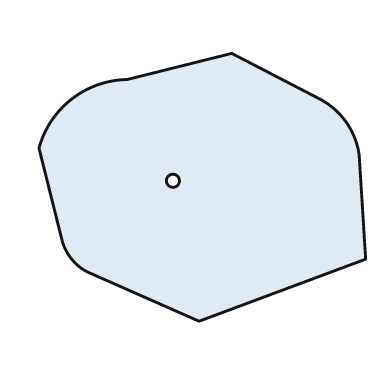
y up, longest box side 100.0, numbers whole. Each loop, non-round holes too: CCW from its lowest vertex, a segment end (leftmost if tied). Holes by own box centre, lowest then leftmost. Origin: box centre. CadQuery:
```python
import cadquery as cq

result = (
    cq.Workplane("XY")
    .moveTo(-1.0, -41.0)
    .lineTo(50.0, -22.0)
    .lineTo(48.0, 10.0)
    .threePointArc((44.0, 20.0), (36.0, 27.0))
    .lineTo(9.0, 41.0)
    .lineTo(-23.0, 33.0)
    .threePointArc((-40.0, 27.0), (-50.0, 12.0))
    .lineTo(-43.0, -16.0)
    .threePointArc((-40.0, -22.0), (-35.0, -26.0))
    .close()
    .moveTo(-9.0, 2.0)
    .circle(2.0)
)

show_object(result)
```